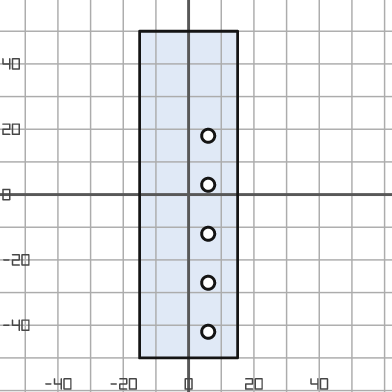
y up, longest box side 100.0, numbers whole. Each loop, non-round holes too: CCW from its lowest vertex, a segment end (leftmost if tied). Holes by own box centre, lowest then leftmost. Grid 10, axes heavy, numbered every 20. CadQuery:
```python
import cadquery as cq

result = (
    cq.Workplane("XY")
    .moveTo(-15.0, -50.0)
    .lineTo(15.0, -50.0)
    .lineTo(15.0, 50.0)
    .lineTo(-15.0, 50.0)
    .close()
    .moveTo(6.0, -42.0)
    .circle(2.0)
    .moveTo(6.0, -27.0)
    .circle(2.0)
    .moveTo(6.0, -12.0)
    .circle(2.0)
    .moveTo(6.0, 3.0)
    .circle(2.0)
    .moveTo(6.0, 18.0)
    .circle(2.0)
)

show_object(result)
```